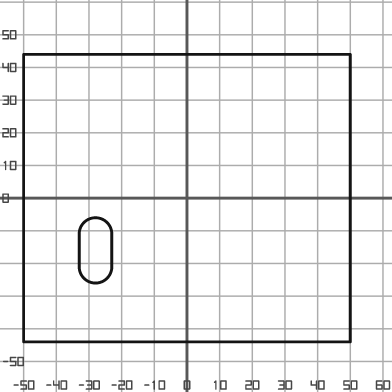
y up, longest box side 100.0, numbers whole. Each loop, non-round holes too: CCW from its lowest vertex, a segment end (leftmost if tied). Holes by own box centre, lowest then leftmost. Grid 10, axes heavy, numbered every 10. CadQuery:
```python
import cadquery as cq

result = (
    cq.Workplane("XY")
    .moveTo(-50.0, -44.0)
    .lineTo(50.0, -44.0)
    .lineTo(50.0, 44.0)
    .lineTo(-50.0, 44.0)
    .close()
    .moveTo(-33.0, -21.0)
    .threePointArc((-28.0, -26.0), (-23.0, -21.0))
    .lineTo(-23.0, -11.0)
    .threePointArc((-28.0, -6.0), (-33.0, -11.0))
    .close()
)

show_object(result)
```